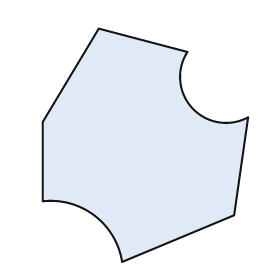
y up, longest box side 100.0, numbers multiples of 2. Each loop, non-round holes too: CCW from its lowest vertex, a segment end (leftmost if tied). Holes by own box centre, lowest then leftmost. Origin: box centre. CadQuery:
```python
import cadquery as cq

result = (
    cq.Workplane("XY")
    .moveTo(-10.0, -50.0)
    .lineTo(38.0, -30.0)
    .lineTo(44.0, 12.0)
    .threePointArc((20.0, 16.0), (18.0, 40.0))
    .lineTo(-20.0, 50.0)
    .lineTo(-44.0, 10.0)
    .lineTo(-44.0, -24.0)
    .threePointArc((-22.0, -30.0), (-10.0, -50.0))
    .close()
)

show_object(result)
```